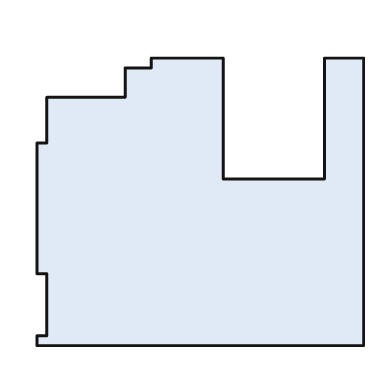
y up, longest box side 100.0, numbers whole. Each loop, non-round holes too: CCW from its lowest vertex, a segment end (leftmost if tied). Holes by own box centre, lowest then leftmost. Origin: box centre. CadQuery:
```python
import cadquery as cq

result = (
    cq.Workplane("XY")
    .moveTo(-50.0, -44.0)
    .lineTo(50.0, -44.0)
    .lineTo(50.0, 44.0)
    .lineTo(38.0, 44.0)
    .lineTo(38.0, 7.0)
    .lineTo(7.0, 7.0)
    .lineTo(7.0, 44.0)
    .lineTo(-15.0, 44.0)
    .lineTo(-15.0, 41.0)
    .lineTo(-23.0, 41.0)
    .lineTo(-23.0, 32.0)
    .lineTo(-47.0, 32.0)
    .lineTo(-47.0, 18.0)
    .lineTo(-50.0, 18.0)
    .lineTo(-50.0, -22.0)
    .lineTo(-47.0, -22.0)
    .lineTo(-47.0, -41.0)
    .lineTo(-50.0, -41.0)
    .close()
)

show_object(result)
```